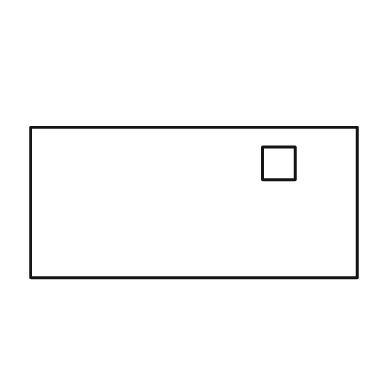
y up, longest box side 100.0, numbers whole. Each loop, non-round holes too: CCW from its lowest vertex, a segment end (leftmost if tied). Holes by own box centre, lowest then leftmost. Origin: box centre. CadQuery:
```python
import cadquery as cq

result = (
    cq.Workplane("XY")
    .moveTo(-50.0, -23.0)
    .lineTo(50.0, -23.0)
    .lineTo(50.0, 23.0)
    .lineTo(-50.0, 23.0)
    .close()
    .moveTo(21.0, 7.0)
    .lineTo(31.0, 7.0)
    .lineTo(31.0, 17.0)
    .lineTo(21.0, 17.0)
    .close()
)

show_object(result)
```